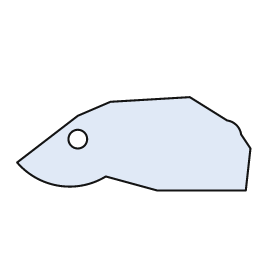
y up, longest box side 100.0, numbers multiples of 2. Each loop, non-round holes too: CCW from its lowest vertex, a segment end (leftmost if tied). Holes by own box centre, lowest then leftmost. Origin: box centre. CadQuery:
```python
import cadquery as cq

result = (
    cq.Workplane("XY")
    .moveTo(10.0, -20.0)
    .lineTo(48.0, -20.0)
    .lineTo(50.0, -2.0)
    .lineTo(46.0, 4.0)
    .threePointArc((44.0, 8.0), (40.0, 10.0))
    .lineTo(24.0, 20.0)
    .lineTo(-10.0, 18.0)
    .lineTo(-24.0, 12.0)
    .lineTo(-50.0, -8.0)
    .threePointArc((-32.0, -18.0), (-12.0, -14.0))
    .close()
    .moveTo(-24.0, 2.0)
    .circle(4.0)
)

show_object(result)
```